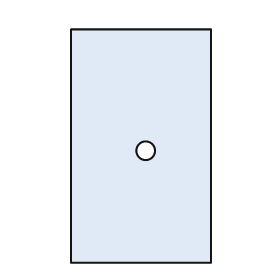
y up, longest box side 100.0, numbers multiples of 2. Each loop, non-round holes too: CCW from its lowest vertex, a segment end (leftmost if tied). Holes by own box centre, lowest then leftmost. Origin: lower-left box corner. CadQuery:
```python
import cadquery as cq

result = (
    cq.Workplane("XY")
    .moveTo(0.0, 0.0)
    .lineTo(60.0, 0.0)
    .lineTo(60.0, 100.0)
    .lineTo(0.0, 100.0)
    .close()
    .moveTo(32.0, 48.0)
    .circle(4.0)
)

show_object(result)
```